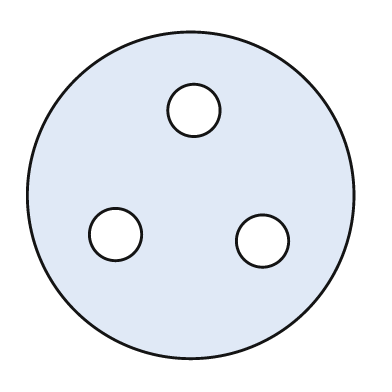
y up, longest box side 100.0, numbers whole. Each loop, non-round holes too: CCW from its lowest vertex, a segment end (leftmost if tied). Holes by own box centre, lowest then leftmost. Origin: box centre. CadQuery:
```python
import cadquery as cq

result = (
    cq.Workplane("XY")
    .moveTo(0.0, 0.0)
    .circle(50.0)
    .moveTo(22.0, -14.0)
    .circle(8.0)
    .moveTo(-23.0, -12.0)
    .circle(8.0)
    .moveTo(1.0, 26.0)
    .circle(8.0)
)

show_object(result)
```